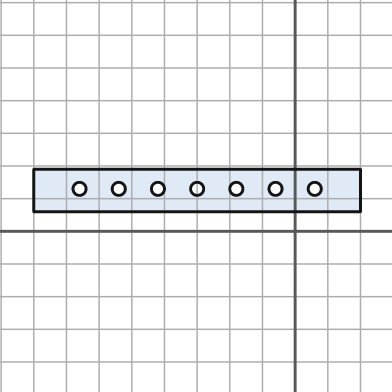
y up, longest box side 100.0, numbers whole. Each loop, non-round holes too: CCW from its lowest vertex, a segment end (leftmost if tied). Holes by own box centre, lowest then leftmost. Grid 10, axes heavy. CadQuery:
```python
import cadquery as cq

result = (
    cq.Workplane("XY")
    .moveTo(-80.0, 6.0)
    .lineTo(20.0, 6.0)
    .lineTo(20.0, 19.0)
    .lineTo(-80.0, 19.0)
    .close()
    .moveTo(-66.0, 13.0)
    .circle(2.0)
    .moveTo(-54.0, 13.0)
    .circle(2.0)
    .moveTo(-42.0, 13.0)
    .circle(2.0)
    .moveTo(-30.0, 13.0)
    .circle(2.0)
    .moveTo(-18.0, 13.0)
    .circle(2.0)
    .moveTo(-6.0, 13.0)
    .circle(2.0)
    .moveTo(6.0, 13.0)
    .circle(2.0)
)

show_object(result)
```